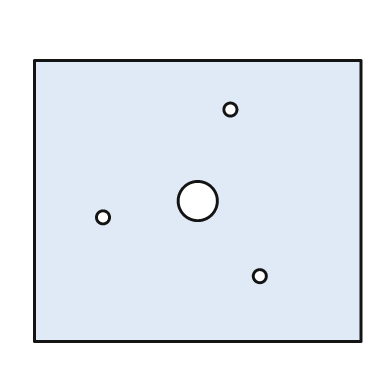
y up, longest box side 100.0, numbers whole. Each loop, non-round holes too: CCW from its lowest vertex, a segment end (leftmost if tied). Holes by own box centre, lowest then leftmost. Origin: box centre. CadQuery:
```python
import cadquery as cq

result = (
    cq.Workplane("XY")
    .moveTo(-50.0, -43.0)
    .lineTo(50.0, -43.0)
    .lineTo(50.0, 43.0)
    .lineTo(-50.0, 43.0)
    .close()
    .moveTo(19.0, -23.0)
    .circle(2.0)
    .moveTo(-29.0, -5.0)
    .circle(2.0)
    .moveTo(0.0, 0.0)
    .circle(6.0)
    .moveTo(10.0, 28.0)
    .circle(2.0)
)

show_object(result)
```